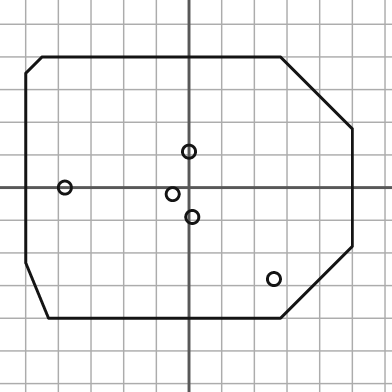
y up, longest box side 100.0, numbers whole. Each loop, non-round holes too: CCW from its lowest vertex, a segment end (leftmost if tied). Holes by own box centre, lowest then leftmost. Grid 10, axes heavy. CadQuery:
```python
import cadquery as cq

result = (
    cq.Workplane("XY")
    .moveTo(-43.0, -40.0)
    .lineTo(28.0, -40.0)
    .lineTo(50.0, -18.0)
    .lineTo(50.0, 18.0)
    .lineTo(28.0, 40.0)
    .lineTo(-45.0, 40.0)
    .lineTo(-50.0, 35.0)
    .lineTo(-50.0, -23.0)
    .close()
    .moveTo(26.0, -28.0)
    .circle(2.0)
    .moveTo(1.0, -9.0)
    .circle(2.0)
    .moveTo(-5.0, -2.0)
    .circle(2.0)
    .moveTo(-38.0, 0.0)
    .circle(2.0)
    .moveTo(0.0, 11.0)
    .circle(2.0)
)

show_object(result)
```